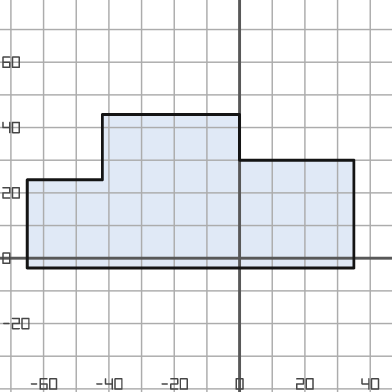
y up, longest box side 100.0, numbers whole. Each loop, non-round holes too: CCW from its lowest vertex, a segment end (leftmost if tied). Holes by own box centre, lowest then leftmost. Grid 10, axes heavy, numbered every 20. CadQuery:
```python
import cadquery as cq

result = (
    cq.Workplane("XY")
    .moveTo(-65.0, -3.0)
    .lineTo(35.0, -3.0)
    .lineTo(35.0, 30.0)
    .lineTo(0.0, 30.0)
    .lineTo(0.0, 44.0)
    .lineTo(-42.0, 44.0)
    .lineTo(-42.0, 24.0)
    .lineTo(-65.0, 24.0)
    .close()
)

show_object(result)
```